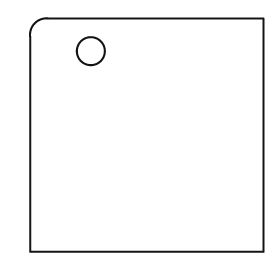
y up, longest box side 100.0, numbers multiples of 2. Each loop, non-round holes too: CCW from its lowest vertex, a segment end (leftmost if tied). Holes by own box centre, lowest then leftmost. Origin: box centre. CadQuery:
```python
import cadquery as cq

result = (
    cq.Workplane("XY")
    .moveTo(-50.0, -50.0)
    .lineTo(50.0, -50.0)
    .lineTo(50.0, 50.0)
    .lineTo(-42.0, 50.0)
    .threePointArc((-48.0, 48.0), (-50.0, 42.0))
    .close()
    .moveTo(-24.0, 36.0)
    .circle(6.0)
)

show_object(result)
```